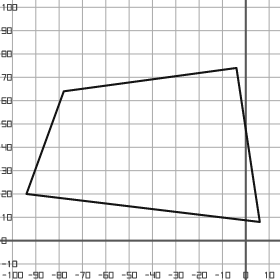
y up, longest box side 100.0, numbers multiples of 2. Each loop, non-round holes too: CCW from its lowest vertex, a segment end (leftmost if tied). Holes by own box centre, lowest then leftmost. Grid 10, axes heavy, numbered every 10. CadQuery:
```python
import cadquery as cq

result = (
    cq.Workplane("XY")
    .moveTo(6.0, 8.0)
    .lineTo(-4.0, 74.0)
    .lineTo(-78.0, 64.0)
    .lineTo(-94.0, 20.0)
    .close()
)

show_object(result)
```